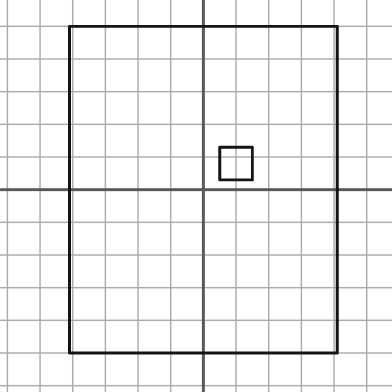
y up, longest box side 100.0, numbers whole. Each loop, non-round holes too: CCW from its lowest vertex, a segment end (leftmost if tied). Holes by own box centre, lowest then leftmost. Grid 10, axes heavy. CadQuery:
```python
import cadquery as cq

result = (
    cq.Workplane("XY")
    .moveTo(-41.0, -50.0)
    .lineTo(41.0, -50.0)
    .lineTo(41.0, 50.0)
    .lineTo(-41.0, 50.0)
    .close()
    .moveTo(5.0, 3.0)
    .lineTo(15.0, 3.0)
    .lineTo(15.0, 13.0)
    .lineTo(5.0, 13.0)
    .close()
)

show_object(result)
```